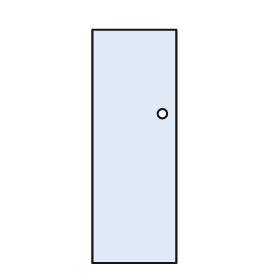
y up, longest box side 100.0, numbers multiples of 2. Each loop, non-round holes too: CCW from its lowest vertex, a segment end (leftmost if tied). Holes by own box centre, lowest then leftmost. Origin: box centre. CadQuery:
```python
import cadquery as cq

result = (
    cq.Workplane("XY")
    .moveTo(-18.0, -50.0)
    .lineTo(18.0, -50.0)
    .lineTo(18.0, 50.0)
    .lineTo(-18.0, 50.0)
    .close()
    .moveTo(12.0, 14.0)
    .circle(2.0)
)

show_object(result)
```